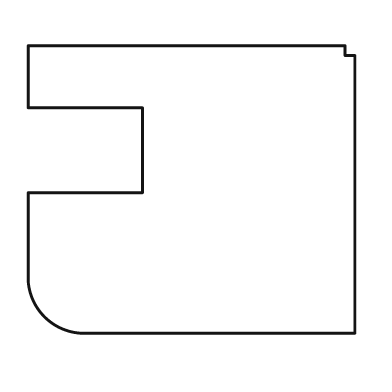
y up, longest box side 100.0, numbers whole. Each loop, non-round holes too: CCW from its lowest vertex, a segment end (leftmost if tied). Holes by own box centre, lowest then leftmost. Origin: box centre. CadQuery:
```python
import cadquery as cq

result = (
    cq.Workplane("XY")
    .moveTo(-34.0, -44.0)
    .lineTo(50.0, -44.0)
    .lineTo(50.0, 41.0)
    .lineTo(47.0, 41.0)
    .lineTo(47.0, 44.0)
    .lineTo(-50.0, 44.0)
    .lineTo(-50.0, 25.0)
    .lineTo(-15.0, 25.0)
    .lineTo(-15.0, -1.0)
    .lineTo(-50.0, -1.0)
    .lineTo(-50.0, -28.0)
    .threePointArc((-45.0, -39.0), (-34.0, -44.0))
    .close()
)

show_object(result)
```